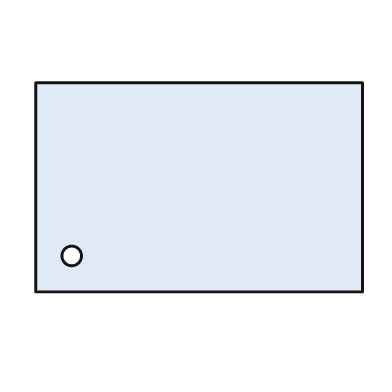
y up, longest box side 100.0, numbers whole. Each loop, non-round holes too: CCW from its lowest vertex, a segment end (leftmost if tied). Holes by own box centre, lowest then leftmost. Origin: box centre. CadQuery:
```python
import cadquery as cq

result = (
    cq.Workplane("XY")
    .moveTo(-50.0, -32.0)
    .lineTo(50.0, -32.0)
    .lineTo(50.0, 32.0)
    .lineTo(-50.0, 32.0)
    .close()
    .moveTo(-39.0, -21.0)
    .circle(3.0)
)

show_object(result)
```